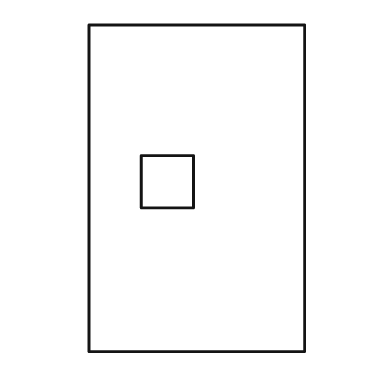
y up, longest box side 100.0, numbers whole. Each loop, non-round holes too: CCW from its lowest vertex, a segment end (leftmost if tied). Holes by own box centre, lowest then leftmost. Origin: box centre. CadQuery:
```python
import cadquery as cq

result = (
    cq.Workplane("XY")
    .moveTo(-33.0, -50.0)
    .lineTo(33.0, -50.0)
    .lineTo(33.0, 50.0)
    .lineTo(-33.0, 50.0)
    .close()
    .moveTo(-17.0, -6.0)
    .lineTo(-1.0, -6.0)
    .lineTo(-1.0, 10.0)
    .lineTo(-17.0, 10.0)
    .close()
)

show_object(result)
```